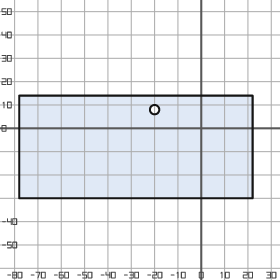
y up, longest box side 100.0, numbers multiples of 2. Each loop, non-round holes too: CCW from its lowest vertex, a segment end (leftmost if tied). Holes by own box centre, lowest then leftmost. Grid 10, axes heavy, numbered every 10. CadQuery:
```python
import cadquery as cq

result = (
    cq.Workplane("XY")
    .moveTo(-78.0, -30.0)
    .lineTo(22.0, -30.0)
    .lineTo(22.0, 14.0)
    .lineTo(-78.0, 14.0)
    .close()
    .moveTo(-20.0, 8.0)
    .circle(2.0)
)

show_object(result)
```